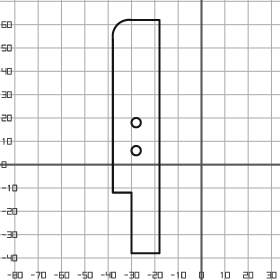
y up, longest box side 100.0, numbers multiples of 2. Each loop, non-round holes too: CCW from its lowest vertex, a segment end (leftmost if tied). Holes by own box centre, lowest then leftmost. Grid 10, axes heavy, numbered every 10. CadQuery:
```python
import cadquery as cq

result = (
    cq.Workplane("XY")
    .moveTo(-30.0, -38.0)
    .lineTo(-18.0, -38.0)
    .lineTo(-18.0, 62.0)
    .lineTo(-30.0, 62.0)
    .threePointArc((-36.0, 60.0), (-38.0, 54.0))
    .lineTo(-38.0, -12.0)
    .lineTo(-30.0, -12.0)
    .close()
    .moveTo(-28.0, 6.0)
    .circle(2.0)
    .moveTo(-28.0, 18.0)
    .circle(2.0)
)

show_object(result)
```